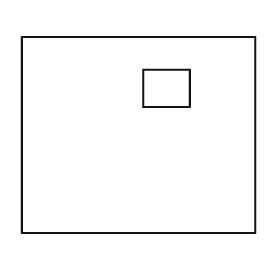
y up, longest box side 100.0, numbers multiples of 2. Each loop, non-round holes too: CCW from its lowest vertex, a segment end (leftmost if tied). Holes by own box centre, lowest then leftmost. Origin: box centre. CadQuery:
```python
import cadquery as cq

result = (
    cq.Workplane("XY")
    .moveTo(-50.0, -42.0)
    .lineTo(50.0, -42.0)
    .lineTo(50.0, 42.0)
    .lineTo(-50.0, 42.0)
    .close()
    .moveTo(2.0, 12.0)
    .lineTo(22.0, 12.0)
    .lineTo(22.0, 28.0)
    .lineTo(2.0, 28.0)
    .close()
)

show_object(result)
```